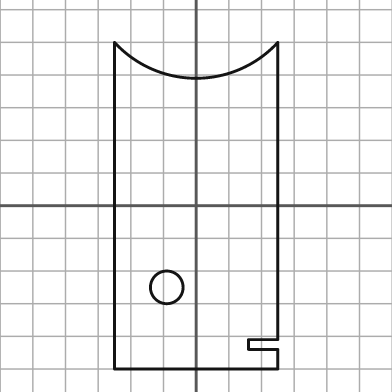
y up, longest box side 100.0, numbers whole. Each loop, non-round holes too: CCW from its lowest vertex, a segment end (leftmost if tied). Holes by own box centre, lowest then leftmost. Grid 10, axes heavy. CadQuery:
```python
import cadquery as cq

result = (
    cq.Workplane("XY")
    .moveTo(-25.0, -50.0)
    .lineTo(25.0, -50.0)
    .lineTo(25.0, -44.0)
    .lineTo(16.0, -44.0)
    .lineTo(16.0, -41.0)
    .lineTo(25.0, -41.0)
    .lineTo(25.0, 50.0)
    .threePointArc((0.0, 39.0), (-25.0, 50.0))
    .close()
    .moveTo(-9.0, -25.0)
    .circle(5.0)
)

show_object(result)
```